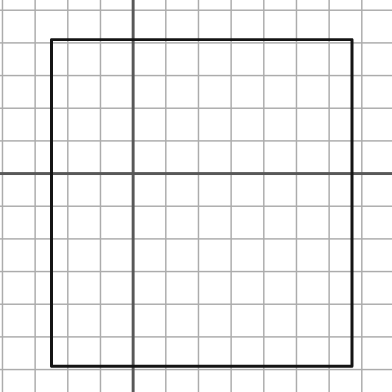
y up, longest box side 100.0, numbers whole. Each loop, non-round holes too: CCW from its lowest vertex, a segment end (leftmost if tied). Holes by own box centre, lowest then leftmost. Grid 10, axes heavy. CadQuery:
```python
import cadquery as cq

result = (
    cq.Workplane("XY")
    .moveTo(-25.0, -59.0)
    .lineTo(67.0, -59.0)
    .lineTo(67.0, 41.0)
    .lineTo(-25.0, 41.0)
    .close()
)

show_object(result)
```